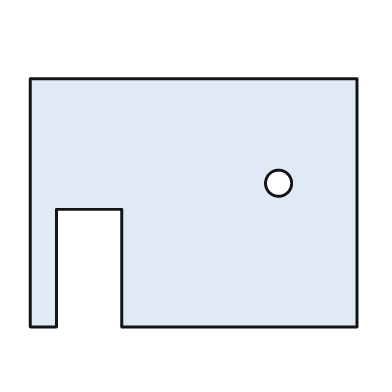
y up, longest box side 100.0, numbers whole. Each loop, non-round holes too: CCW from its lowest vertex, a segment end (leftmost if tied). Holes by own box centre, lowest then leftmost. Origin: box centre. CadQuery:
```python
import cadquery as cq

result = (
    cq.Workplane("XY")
    .moveTo(-50.0, -38.0)
    .lineTo(-42.0, -38.0)
    .lineTo(-42.0, -2.0)
    .lineTo(-22.0, -2.0)
    .lineTo(-22.0, -38.0)
    .lineTo(50.0, -38.0)
    .lineTo(50.0, 38.0)
    .lineTo(-50.0, 38.0)
    .close()
    .moveTo(26.0, 6.0)
    .circle(4.0)
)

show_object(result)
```